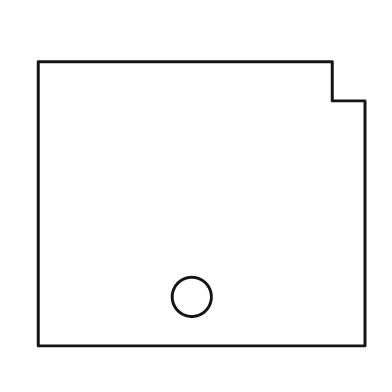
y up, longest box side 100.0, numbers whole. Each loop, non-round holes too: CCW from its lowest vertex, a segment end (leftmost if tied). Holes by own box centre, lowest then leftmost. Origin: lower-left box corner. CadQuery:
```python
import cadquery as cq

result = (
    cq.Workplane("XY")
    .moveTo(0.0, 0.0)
    .lineTo(100.0, 0.0)
    .lineTo(100.0, 75.0)
    .lineTo(90.0, 75.0)
    .lineTo(90.0, 87.0)
    .lineTo(0.0, 87.0)
    .close()
    .moveTo(47.0, 15.0)
    .circle(6.0)
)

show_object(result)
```